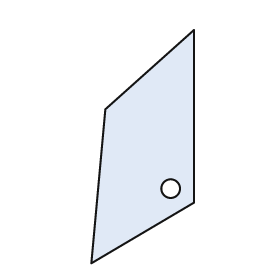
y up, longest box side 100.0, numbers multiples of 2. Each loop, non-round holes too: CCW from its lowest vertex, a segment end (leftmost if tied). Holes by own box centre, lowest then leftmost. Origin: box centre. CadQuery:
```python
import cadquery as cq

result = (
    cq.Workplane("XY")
    .moveTo(-22.0, -50.0)
    .lineTo(22.0, -24.0)
    .lineTo(22.0, 50.0)
    .lineTo(-16.0, 16.0)
    .close()
    .moveTo(12.0, -18.0)
    .circle(4.0)
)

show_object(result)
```